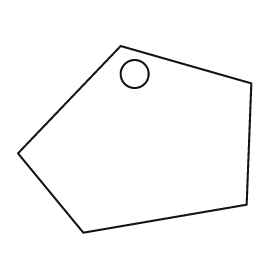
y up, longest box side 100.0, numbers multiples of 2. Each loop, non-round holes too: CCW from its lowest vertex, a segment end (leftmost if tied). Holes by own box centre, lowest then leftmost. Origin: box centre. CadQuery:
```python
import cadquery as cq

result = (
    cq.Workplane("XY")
    .moveTo(-22.0, -40.0)
    .lineTo(48.0, -28.0)
    .lineTo(50.0, 24.0)
    .lineTo(-6.0, 40.0)
    .lineTo(-50.0, -6.0)
    .close()
    .moveTo(0.0, 28.0)
    .circle(6.0)
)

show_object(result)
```